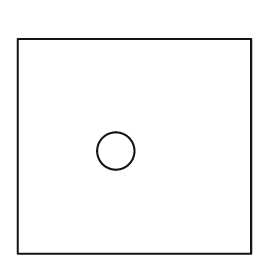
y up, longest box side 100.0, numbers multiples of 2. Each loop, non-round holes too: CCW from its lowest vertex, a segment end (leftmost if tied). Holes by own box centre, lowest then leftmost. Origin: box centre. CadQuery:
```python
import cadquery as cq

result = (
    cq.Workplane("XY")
    .moveTo(-50.0, -46.0)
    .lineTo(50.0, -46.0)
    .lineTo(50.0, 46.0)
    .lineTo(-50.0, 46.0)
    .close()
    .moveTo(-8.0, -2.0)
    .circle(8.0)
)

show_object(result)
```